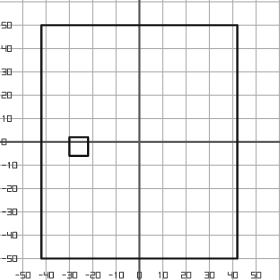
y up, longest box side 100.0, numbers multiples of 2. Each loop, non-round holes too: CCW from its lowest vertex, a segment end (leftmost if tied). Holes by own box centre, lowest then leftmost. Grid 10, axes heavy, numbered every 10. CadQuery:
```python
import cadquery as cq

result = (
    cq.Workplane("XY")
    .moveTo(-42.0, -50.0)
    .lineTo(42.0, -50.0)
    .lineTo(42.0, 50.0)
    .lineTo(-42.0, 50.0)
    .close()
    .moveTo(-30.0, -6.0)
    .lineTo(-22.0, -6.0)
    .lineTo(-22.0, 2.0)
    .lineTo(-30.0, 2.0)
    .close()
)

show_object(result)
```